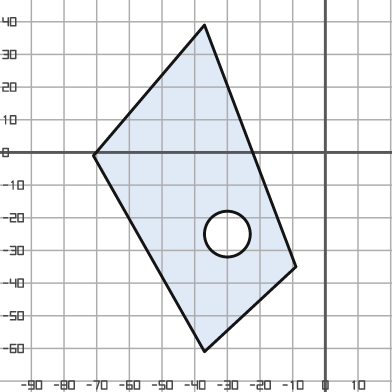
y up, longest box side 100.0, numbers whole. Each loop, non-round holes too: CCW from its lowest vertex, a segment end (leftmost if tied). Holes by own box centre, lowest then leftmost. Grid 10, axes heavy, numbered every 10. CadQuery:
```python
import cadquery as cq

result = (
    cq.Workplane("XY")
    .moveTo(-37.0, -61.0)
    .lineTo(-9.0, -35.0)
    .lineTo(-37.0, 39.0)
    .lineTo(-71.0, -1.0)
    .close()
    .moveTo(-30.0, -25.0)
    .circle(7.0)
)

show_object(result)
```